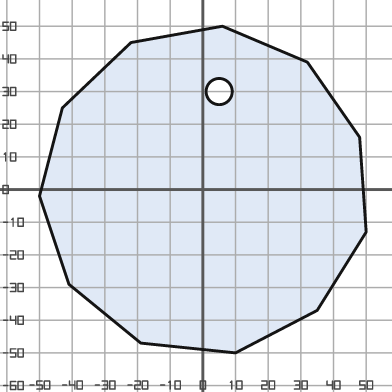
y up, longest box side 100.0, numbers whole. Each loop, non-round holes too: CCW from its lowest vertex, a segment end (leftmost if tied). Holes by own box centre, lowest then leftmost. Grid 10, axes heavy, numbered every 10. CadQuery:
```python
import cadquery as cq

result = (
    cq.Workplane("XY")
    .moveTo(10.0, -50.0)
    .lineTo(35.0, -37.0)
    .lineTo(50.0, -13.0)
    .lineTo(48.0, 16.0)
    .lineTo(32.0, 39.0)
    .lineTo(6.0, 50.0)
    .lineTo(-22.0, 45.0)
    .lineTo(-43.0, 25.0)
    .lineTo(-50.0, -2.0)
    .lineTo(-41.0, -29.0)
    .lineTo(-19.0, -47.0)
    .close()
    .moveTo(5.0, 30.0)
    .circle(4.0)
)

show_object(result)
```